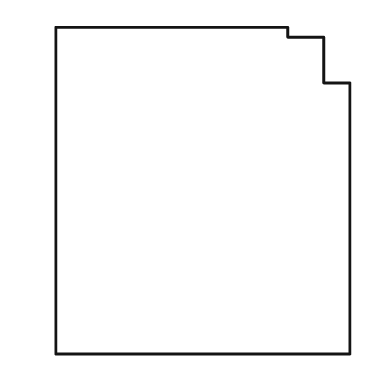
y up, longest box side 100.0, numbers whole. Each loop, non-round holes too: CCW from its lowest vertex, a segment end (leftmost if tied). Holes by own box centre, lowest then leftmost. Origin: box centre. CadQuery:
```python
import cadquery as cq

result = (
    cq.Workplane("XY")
    .moveTo(-45.0, -50.0)
    .lineTo(45.0, -50.0)
    .lineTo(45.0, 33.0)
    .lineTo(37.0, 33.0)
    .lineTo(37.0, 47.0)
    .lineTo(26.0, 47.0)
    .lineTo(26.0, 50.0)
    .lineTo(-45.0, 50.0)
    .close()
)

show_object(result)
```